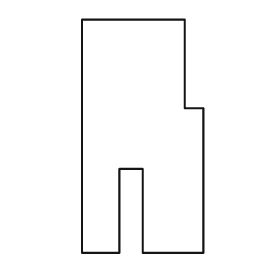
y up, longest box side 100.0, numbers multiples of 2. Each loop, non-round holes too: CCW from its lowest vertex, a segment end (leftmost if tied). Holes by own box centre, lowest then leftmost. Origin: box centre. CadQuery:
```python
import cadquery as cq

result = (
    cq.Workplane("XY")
    .moveTo(-26.0, -50.0)
    .lineTo(-10.0, -50.0)
    .lineTo(-10.0, -14.0)
    .lineTo(0.0, -14.0)
    .lineTo(0.0, -50.0)
    .lineTo(26.0, -50.0)
    .lineTo(26.0, 12.0)
    .lineTo(18.0, 12.0)
    .lineTo(18.0, 50.0)
    .lineTo(-26.0, 50.0)
    .close()
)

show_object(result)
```